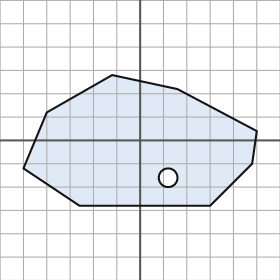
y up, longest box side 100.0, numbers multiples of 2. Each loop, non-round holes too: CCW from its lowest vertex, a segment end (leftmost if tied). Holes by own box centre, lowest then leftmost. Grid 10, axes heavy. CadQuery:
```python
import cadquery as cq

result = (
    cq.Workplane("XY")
    .moveTo(-26.0, -28.0)
    .lineTo(30.0, -28.0)
    .lineTo(48.0, -10.0)
    .lineTo(50.0, 4.0)
    .lineTo(16.0, 22.0)
    .lineTo(-12.0, 28.0)
    .lineTo(-40.0, 12.0)
    .lineTo(-50.0, -12.0)
    .close()
    .moveTo(12.0, -16.0)
    .circle(4.0)
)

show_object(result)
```